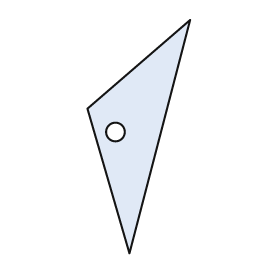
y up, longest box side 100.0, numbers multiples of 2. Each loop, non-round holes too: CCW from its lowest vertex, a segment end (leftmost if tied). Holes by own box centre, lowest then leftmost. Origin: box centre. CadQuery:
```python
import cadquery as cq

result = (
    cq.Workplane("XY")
    .moveTo(-4.0, -50.0)
    .lineTo(22.0, 50.0)
    .lineTo(-22.0, 12.0)
    .close()
    .moveTo(-10.0, 2.0)
    .circle(4.0)
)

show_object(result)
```